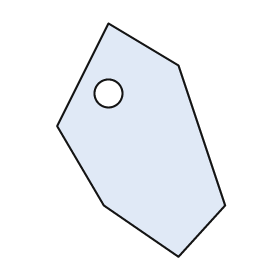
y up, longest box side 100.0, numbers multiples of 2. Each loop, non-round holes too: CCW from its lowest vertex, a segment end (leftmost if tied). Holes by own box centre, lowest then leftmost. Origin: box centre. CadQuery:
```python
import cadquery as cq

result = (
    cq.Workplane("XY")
    .moveTo(16.0, -50.0)
    .lineTo(36.0, -28.0)
    .lineTo(16.0, 32.0)
    .lineTo(-14.0, 50.0)
    .lineTo(-36.0, 6.0)
    .lineTo(-16.0, -28.0)
    .close()
    .moveTo(-14.0, 20.0)
    .circle(6.0)
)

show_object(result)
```